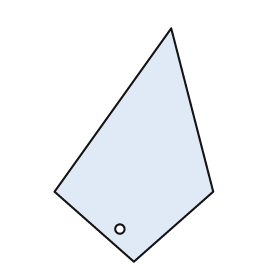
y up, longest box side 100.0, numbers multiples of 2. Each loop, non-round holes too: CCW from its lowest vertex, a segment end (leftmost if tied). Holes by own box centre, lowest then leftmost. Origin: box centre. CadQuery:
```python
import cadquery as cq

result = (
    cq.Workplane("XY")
    .moveTo(0.0, -50.0)
    .lineTo(34.0, -20.0)
    .lineTo(16.0, 50.0)
    .lineTo(-34.0, -20.0)
    .close()
    .moveTo(-6.0, -36.0)
    .circle(2.0)
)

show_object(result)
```